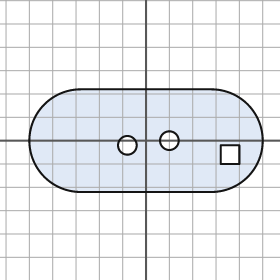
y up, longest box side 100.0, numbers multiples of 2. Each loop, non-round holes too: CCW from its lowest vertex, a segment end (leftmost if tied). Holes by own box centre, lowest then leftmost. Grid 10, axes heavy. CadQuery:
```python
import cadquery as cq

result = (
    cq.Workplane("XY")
    .moveTo(-28.0, -22.0)
    .lineTo(28.0, -22.0)
    .threePointArc((50.0, 0.0), (28.0, 22.0))
    .lineTo(-28.0, 22.0)
    .threePointArc((-50.0, 0.0), (-28.0, -22.0))
    .close()
    .moveTo(32.0, -10.0)
    .lineTo(40.0, -10.0)
    .lineTo(40.0, -2.0)
    .lineTo(32.0, -2.0)
    .close()
    .moveTo(-8.0, -2.0)
    .circle(4.0)
    .moveTo(10.0, 0.0)
    .circle(4.0)
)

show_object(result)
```